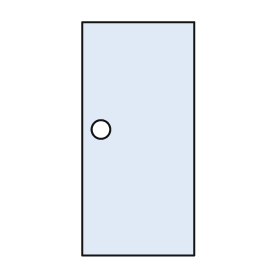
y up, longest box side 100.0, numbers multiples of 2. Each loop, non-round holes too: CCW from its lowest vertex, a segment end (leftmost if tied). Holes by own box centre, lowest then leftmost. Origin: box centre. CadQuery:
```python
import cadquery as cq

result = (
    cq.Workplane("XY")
    .moveTo(-24.0, -50.0)
    .lineTo(24.0, -50.0)
    .lineTo(24.0, 50.0)
    .lineTo(-24.0, 50.0)
    .close()
    .moveTo(-16.0, 4.0)
    .circle(4.0)
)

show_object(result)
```